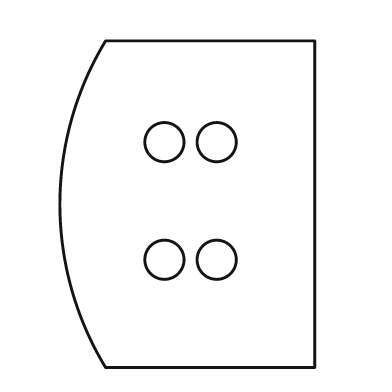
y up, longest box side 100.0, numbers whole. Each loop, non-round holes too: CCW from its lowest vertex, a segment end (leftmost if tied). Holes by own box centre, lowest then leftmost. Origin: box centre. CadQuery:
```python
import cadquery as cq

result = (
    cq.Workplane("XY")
    .moveTo(-25.0, -50.0)
    .lineTo(39.0, -50.0)
    .lineTo(39.0, 50.0)
    .lineTo(-25.0, 50.0)
    .threePointArc((-39.0, 0.0), (-25.0, -50.0))
    .close()
    .moveTo(-7.0, -17.0)
    .circle(6.0)
    .moveTo(9.0, -17.0)
    .circle(6.0)
    .moveTo(-7.0, 19.0)
    .circle(6.0)
    .moveTo(9.0, 19.0)
    .circle(6.0)
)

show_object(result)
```